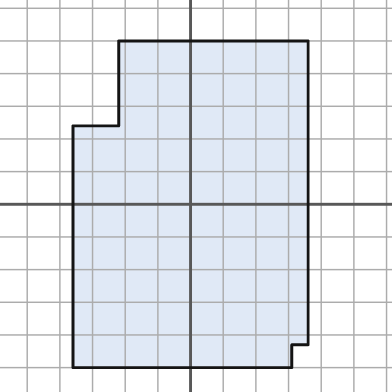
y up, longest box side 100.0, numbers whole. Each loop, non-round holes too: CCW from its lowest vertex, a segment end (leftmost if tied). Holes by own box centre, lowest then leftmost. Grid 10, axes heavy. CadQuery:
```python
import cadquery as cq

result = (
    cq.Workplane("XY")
    .moveTo(-36.0, -50.0)
    .lineTo(31.0, -50.0)
    .lineTo(31.0, -43.0)
    .lineTo(36.0, -43.0)
    .lineTo(36.0, 50.0)
    .lineTo(-22.0, 50.0)
    .lineTo(-22.0, 24.0)
    .lineTo(-36.0, 24.0)
    .close()
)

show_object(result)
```